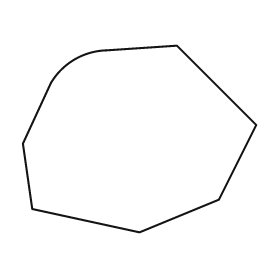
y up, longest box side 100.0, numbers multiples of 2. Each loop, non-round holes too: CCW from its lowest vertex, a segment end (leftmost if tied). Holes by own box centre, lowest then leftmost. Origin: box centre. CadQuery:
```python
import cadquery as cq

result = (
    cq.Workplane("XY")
    .moveTo(0.0, -40.0)
    .lineTo(34.0, -26.0)
    .lineTo(50.0, 6.0)
    .lineTo(16.0, 40.0)
    .lineTo(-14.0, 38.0)
    .threePointArc((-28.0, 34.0), (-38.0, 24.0))
    .lineTo(-50.0, -2.0)
    .lineTo(-46.0, -30.0)
    .close()
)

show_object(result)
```